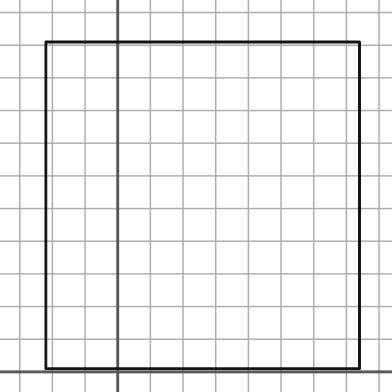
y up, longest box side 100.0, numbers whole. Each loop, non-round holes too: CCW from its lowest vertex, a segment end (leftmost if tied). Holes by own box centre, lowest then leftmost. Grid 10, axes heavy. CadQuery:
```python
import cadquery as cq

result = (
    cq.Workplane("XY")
    .moveTo(-22.0, 1.0)
    .lineTo(74.0, 1.0)
    .lineTo(74.0, 101.0)
    .lineTo(-22.0, 101.0)
    .close()
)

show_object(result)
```